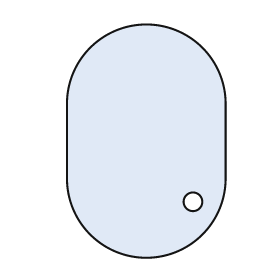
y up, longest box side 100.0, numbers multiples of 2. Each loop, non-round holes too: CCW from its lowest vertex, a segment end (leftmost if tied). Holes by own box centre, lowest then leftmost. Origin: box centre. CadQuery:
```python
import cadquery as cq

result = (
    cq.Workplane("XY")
    .moveTo(-34.0, -16.0)
    .threePointArc((0.0, -50.0), (34.0, -16.0))
    .lineTo(34.0, 16.0)
    .threePointArc((0.0, 50.0), (-34.0, 16.0))
    .close()
    .moveTo(20.0, -26.0)
    .circle(4.0)
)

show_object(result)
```